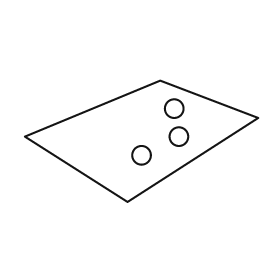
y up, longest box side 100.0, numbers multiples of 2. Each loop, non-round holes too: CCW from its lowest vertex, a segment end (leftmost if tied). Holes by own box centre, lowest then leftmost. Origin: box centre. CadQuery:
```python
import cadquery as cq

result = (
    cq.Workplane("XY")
    .moveTo(-6.0, -26.0)
    .lineTo(50.0, 10.0)
    .lineTo(8.0, 26.0)
    .lineTo(-50.0, 2.0)
    .close()
    .moveTo(0.0, -6.0)
    .circle(4.0)
    .moveTo(16.0, 2.0)
    .circle(4.0)
    .moveTo(14.0, 14.0)
    .circle(4.0)
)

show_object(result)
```